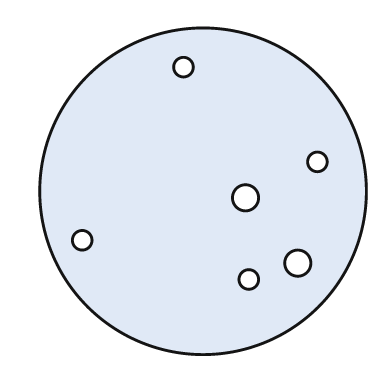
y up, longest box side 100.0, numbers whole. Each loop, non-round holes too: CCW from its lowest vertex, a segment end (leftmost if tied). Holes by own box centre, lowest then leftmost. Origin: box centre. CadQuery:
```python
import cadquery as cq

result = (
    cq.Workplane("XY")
    .moveTo(0.0, 0.0)
    .circle(50.0)
    .moveTo(14.0, -27.0)
    .circle(3.0)
    .moveTo(29.0, -22.0)
    .circle(4.0)
    .moveTo(-37.0, -15.0)
    .circle(3.0)
    .moveTo(13.0, -2.0)
    .circle(4.0)
    .moveTo(35.0, 9.0)
    .circle(3.0)
    .moveTo(-6.0, 38.0)
    .circle(3.0)
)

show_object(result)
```